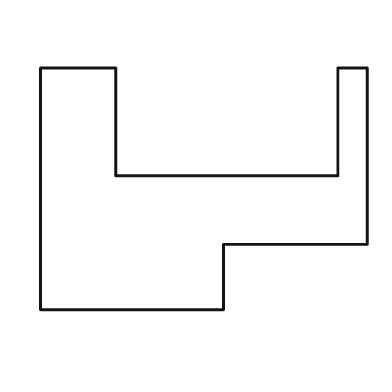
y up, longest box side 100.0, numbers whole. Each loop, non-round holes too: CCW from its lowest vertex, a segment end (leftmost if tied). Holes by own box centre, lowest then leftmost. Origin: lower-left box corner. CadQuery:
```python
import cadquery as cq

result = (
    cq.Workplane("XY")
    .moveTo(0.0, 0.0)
    .lineTo(56.0, 0.0)
    .lineTo(56.0, 20.0)
    .lineTo(100.0, 20.0)
    .lineTo(100.0, 74.0)
    .lineTo(91.0, 74.0)
    .lineTo(91.0, 41.0)
    .lineTo(23.0, 41.0)
    .lineTo(23.0, 74.0)
    .lineTo(0.0, 74.0)
    .close()
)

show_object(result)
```